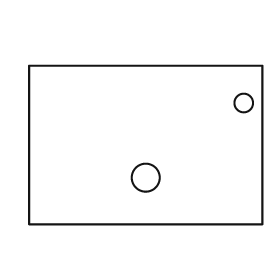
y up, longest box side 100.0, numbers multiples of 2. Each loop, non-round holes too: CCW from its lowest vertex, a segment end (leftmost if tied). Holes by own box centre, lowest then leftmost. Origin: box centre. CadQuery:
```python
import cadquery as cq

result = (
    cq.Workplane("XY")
    .moveTo(-50.0, -34.0)
    .lineTo(50.0, -34.0)
    .lineTo(50.0, 34.0)
    .lineTo(-50.0, 34.0)
    .close()
    .moveTo(0.0, -14.0)
    .circle(6.0)
    .moveTo(42.0, 18.0)
    .circle(4.0)
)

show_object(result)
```